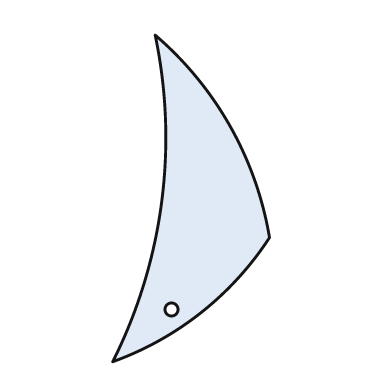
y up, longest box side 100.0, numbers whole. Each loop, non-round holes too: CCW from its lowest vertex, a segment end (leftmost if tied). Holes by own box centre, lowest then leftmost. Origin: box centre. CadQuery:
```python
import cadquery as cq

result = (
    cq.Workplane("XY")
    .moveTo(-24.0, -50.0)
    .threePointArc((3.0, -35.0), (24.0, -12.0))
    .threePointArc((12.0, 22.0), (-11.0, 50.0))
    .threePointArc((-9.0, -1.0), (-24.0, -50.0))
    .close()
    .moveTo(-6.0, -34.0)
    .circle(2.0)
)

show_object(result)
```